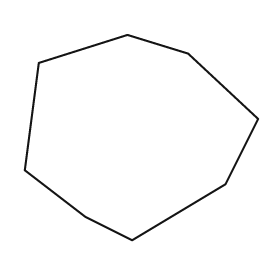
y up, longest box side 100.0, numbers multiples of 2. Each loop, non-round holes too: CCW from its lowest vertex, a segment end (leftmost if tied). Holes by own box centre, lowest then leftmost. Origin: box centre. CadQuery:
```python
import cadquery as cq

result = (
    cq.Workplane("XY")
    .moveTo(-4.0, -44.0)
    .lineTo(36.0, -20.0)
    .lineTo(50.0, 8.0)
    .lineTo(20.0, 36.0)
    .lineTo(-6.0, 44.0)
    .lineTo(-44.0, 32.0)
    .lineTo(-50.0, -14.0)
    .lineTo(-24.0, -34.0)
    .close()
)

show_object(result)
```